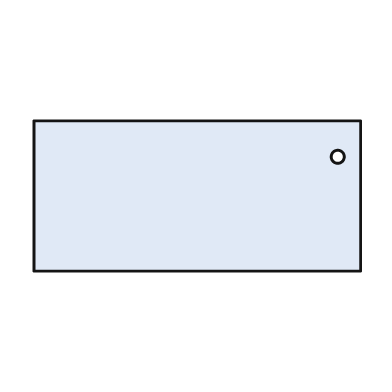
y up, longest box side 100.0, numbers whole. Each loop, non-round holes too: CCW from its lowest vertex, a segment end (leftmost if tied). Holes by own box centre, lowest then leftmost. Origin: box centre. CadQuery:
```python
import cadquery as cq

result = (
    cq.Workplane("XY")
    .moveTo(-50.0, -23.0)
    .lineTo(50.0, -23.0)
    .lineTo(50.0, 23.0)
    .lineTo(-50.0, 23.0)
    .close()
    .moveTo(43.0, 12.0)
    .circle(2.0)
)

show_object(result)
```